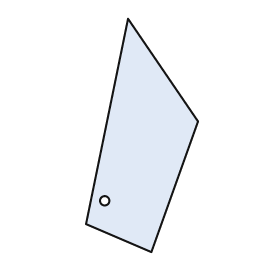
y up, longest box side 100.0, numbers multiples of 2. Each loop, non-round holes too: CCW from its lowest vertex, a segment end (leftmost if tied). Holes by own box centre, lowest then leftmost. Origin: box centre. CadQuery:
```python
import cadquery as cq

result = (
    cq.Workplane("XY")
    .moveTo(4.0, -50.0)
    .lineTo(24.0, 6.0)
    .lineTo(-6.0, 50.0)
    .lineTo(-24.0, -38.0)
    .close()
    .moveTo(-16.0, -28.0)
    .circle(2.0)
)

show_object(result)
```